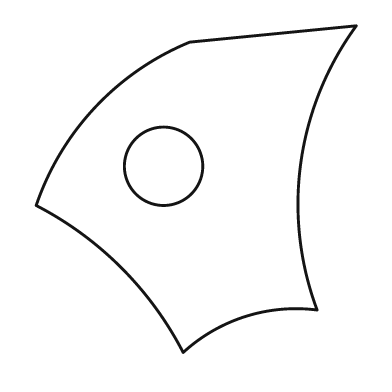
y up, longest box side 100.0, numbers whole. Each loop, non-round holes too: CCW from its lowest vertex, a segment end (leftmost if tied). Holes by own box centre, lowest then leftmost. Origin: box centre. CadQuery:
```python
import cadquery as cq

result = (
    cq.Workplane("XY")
    .moveTo(-4.0, -50.0)
    .threePointArc((15.0, -39.0), (37.0, -37.0))
    .threePointArc((32.0, 8.0), (49.0, 50.0))
    .lineTo(-2.0, 45.0)
    .threePointArc((-31.0, 25.0), (-49.0, -5.0))
    .threePointArc((-23.0, -24.0), (-4.0, -50.0))
    .close()
    .moveTo(-10.0, 7.0)
    .circle(12.0)
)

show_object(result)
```